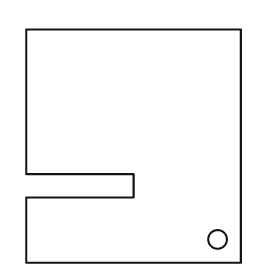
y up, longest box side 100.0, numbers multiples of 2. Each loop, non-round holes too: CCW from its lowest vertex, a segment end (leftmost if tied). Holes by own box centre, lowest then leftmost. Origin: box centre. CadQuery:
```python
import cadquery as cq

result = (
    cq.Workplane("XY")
    .moveTo(-46.0, -50.0)
    .lineTo(46.0, -50.0)
    .lineTo(46.0, 50.0)
    .lineTo(-46.0, 50.0)
    .lineTo(-46.0, -12.0)
    .lineTo(0.0, -12.0)
    .lineTo(0.0, -22.0)
    .lineTo(-46.0, -22.0)
    .close()
    .moveTo(36.0, -40.0)
    .circle(4.0)
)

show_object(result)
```